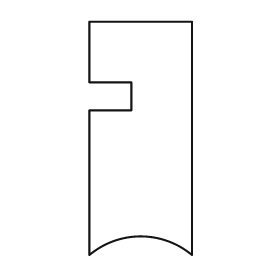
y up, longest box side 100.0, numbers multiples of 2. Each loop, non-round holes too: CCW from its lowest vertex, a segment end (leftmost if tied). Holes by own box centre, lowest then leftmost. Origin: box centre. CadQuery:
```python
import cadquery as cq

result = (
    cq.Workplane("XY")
    .moveTo(-22.0, -50.0)
    .threePointArc((0.0, -42.0), (22.0, -50.0))
    .lineTo(22.0, 50.0)
    .lineTo(-22.0, 50.0)
    .lineTo(-22.0, 24.0)
    .lineTo(-4.0, 24.0)
    .lineTo(-4.0, 12.0)
    .lineTo(-22.0, 12.0)
    .close()
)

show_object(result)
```